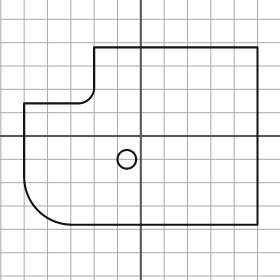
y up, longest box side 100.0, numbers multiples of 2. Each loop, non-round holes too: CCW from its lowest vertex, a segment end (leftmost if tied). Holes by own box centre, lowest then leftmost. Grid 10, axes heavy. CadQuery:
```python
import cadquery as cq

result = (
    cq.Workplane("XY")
    .moveTo(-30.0, -38.0)
    .lineTo(50.0, -38.0)
    .lineTo(50.0, 38.0)
    .lineTo(-20.0, 38.0)
    .lineTo(-20.0, 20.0)
    .threePointArc((-22.0, 16.0), (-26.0, 14.0))
    .lineTo(-50.0, 14.0)
    .lineTo(-50.0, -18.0)
    .threePointArc((-44.0, -32.0), (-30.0, -38.0))
    .close()
    .moveTo(-6.0, -10.0)
    .circle(4.0)
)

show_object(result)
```